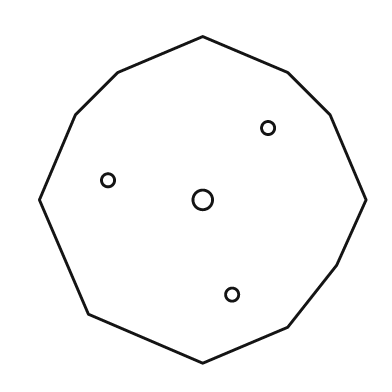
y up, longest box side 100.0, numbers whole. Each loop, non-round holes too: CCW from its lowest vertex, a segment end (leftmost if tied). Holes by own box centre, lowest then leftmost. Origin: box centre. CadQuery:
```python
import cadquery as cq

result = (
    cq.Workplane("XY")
    .moveTo(0.0, -50.0)
    .lineTo(26.0, -39.0)
    .lineTo(41.0, -20.0)
    .lineTo(50.0, 0.0)
    .lineTo(39.0, 26.0)
    .lineTo(26.0, 39.0)
    .lineTo(0.0, 50.0)
    .lineTo(-26.0, 39.0)
    .lineTo(-39.0, 26.0)
    .lineTo(-50.0, 0.0)
    .lineTo(-35.0, -35.0)
    .close()
    .moveTo(9.0, -29.0)
    .circle(2.0)
    .moveTo(0.0, 0.0)
    .circle(3.0)
    .moveTo(-29.0, 6.0)
    .circle(2.0)
    .moveTo(20.0, 22.0)
    .circle(2.0)
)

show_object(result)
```